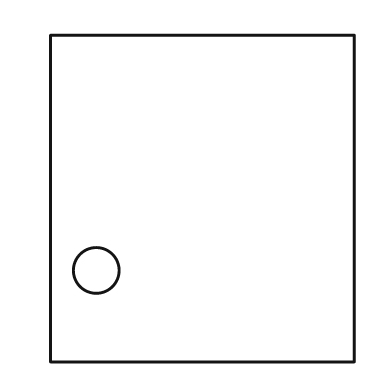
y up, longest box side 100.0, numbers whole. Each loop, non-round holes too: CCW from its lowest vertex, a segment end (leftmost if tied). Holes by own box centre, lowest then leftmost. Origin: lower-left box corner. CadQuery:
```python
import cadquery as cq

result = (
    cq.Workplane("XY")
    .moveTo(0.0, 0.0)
    .lineTo(93.0, 0.0)
    .lineTo(93.0, 100.0)
    .lineTo(0.0, 100.0)
    .close()
    .moveTo(14.0, 28.0)
    .circle(7.0)
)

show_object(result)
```